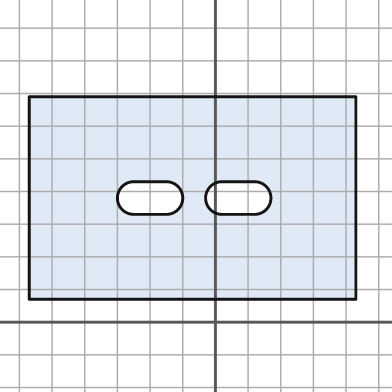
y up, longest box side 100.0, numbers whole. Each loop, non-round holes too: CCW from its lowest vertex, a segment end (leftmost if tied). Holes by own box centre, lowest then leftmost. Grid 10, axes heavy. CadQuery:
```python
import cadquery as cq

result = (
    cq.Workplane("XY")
    .moveTo(-57.0, 7.0)
    .lineTo(43.0, 7.0)
    .lineTo(43.0, 69.0)
    .lineTo(-57.0, 69.0)
    .close()
    .moveTo(-25.0, 33.0)
    .lineTo(-15.0, 33.0)
    .threePointArc((-10.0, 38.0), (-15.0, 43.0))
    .lineTo(-25.0, 43.0)
    .threePointArc((-30.0, 38.0), (-25.0, 33.0))
    .close()
    .moveTo(2.0, 33.0)
    .lineTo(12.0, 33.0)
    .threePointArc((17.0, 38.0), (12.0, 43.0))
    .lineTo(2.0, 43.0)
    .threePointArc((-3.0, 38.0), (2.0, 33.0))
    .close()
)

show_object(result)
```